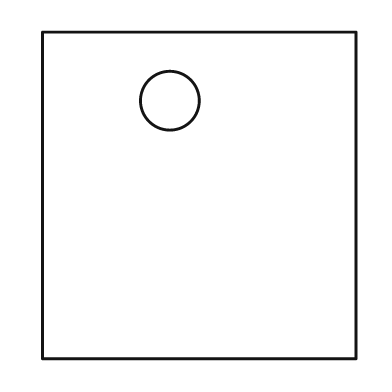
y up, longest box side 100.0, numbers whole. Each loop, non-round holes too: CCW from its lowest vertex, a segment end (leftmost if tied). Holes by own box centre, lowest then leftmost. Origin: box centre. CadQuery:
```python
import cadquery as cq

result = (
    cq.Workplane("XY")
    .moveTo(-48.0, -50.0)
    .lineTo(48.0, -50.0)
    .lineTo(48.0, 50.0)
    .lineTo(-48.0, 50.0)
    .close()
    .moveTo(-9.0, 29.0)
    .circle(9.0)
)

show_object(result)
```